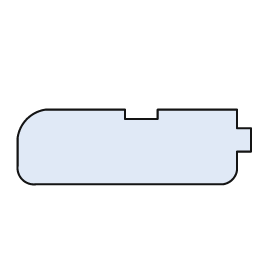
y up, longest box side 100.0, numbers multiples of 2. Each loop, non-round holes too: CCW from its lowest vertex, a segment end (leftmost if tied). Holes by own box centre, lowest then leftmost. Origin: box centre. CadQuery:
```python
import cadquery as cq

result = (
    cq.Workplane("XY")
    .moveTo(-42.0, -16.0)
    .lineTo(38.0, -16.0)
    .threePointArc((42.0, -14.0), (44.0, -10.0))
    .lineTo(44.0, -2.0)
    .lineTo(50.0, -2.0)
    .lineTo(50.0, 8.0)
    .lineTo(44.0, 8.0)
    .lineTo(44.0, 16.0)
    .lineTo(10.0, 16.0)
    .lineTo(10.0, 12.0)
    .lineTo(-4.0, 12.0)
    .lineTo(-4.0, 16.0)
    .lineTo(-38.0, 16.0)
    .threePointArc((-46.0, 12.0), (-50.0, 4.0))
    .lineTo(-50.0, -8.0)
    .threePointArc((-48.0, -14.0), (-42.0, -16.0))
    .close()
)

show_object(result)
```